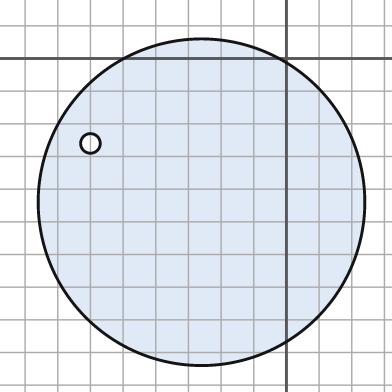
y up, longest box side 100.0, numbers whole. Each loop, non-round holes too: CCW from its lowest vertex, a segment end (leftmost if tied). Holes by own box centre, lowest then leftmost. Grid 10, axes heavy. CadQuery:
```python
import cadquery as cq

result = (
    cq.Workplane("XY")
    .moveTo(-26.0, -44.0)
    .circle(50.0)
    .moveTo(-60.0, -26.0)
    .circle(3.0)
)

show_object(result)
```